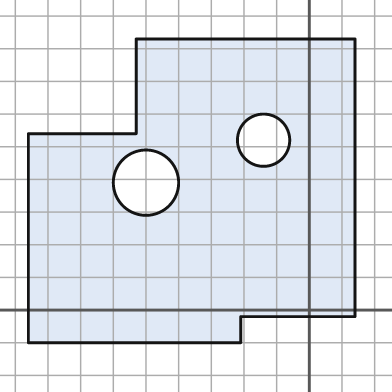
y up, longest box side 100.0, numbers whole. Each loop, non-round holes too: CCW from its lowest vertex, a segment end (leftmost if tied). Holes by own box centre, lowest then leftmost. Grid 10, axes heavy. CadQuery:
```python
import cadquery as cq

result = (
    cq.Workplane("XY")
    .moveTo(-86.0, -10.0)
    .lineTo(-21.0, -10.0)
    .lineTo(-21.0, -2.0)
    .lineTo(14.0, -2.0)
    .lineTo(14.0, 83.0)
    .lineTo(-53.0, 83.0)
    .lineTo(-53.0, 54.0)
    .lineTo(-86.0, 54.0)
    .close()
    .moveTo(-50.0, 39.0)
    .circle(10.0)
    .moveTo(-14.0, 52.0)
    .circle(8.0)
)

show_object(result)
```